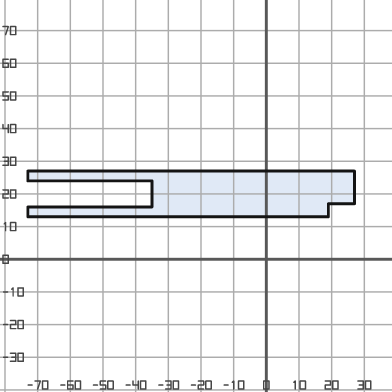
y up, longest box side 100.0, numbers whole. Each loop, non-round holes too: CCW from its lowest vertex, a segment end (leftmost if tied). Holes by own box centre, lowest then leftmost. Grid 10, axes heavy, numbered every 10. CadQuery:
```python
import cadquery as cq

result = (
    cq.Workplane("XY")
    .moveTo(-73.0, 13.0)
    .lineTo(19.0, 13.0)
    .lineTo(19.0, 17.0)
    .lineTo(27.0, 17.0)
    .lineTo(27.0, 27.0)
    .lineTo(-73.0, 27.0)
    .lineTo(-73.0, 24.0)
    .lineTo(-35.0, 24.0)
    .lineTo(-35.0, 16.0)
    .lineTo(-73.0, 16.0)
    .close()
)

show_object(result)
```